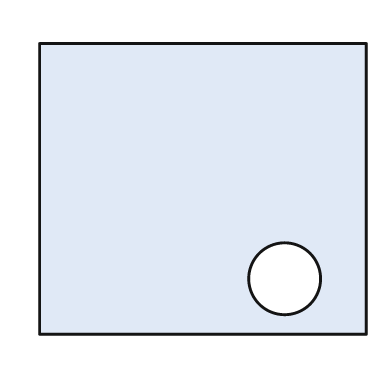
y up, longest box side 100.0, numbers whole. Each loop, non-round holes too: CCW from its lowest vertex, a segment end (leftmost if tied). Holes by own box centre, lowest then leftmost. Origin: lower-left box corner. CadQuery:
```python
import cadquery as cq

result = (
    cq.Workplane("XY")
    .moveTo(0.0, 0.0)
    .lineTo(100.0, 0.0)
    .lineTo(100.0, 89.0)
    .lineTo(0.0, 89.0)
    .close()
    .moveTo(75.0, 17.0)
    .circle(11.0)
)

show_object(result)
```